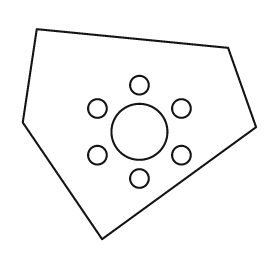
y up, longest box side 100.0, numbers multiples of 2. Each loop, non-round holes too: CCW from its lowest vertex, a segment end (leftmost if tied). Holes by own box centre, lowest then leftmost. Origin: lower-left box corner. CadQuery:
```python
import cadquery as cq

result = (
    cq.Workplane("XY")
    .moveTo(34.0, 0.0)
    .lineTo(100.0, 48.0)
    .lineTo(88.0, 82.0)
    .lineTo(6.0, 90.0)
    .lineTo(0.0, 50.0)
    .close()
    .moveTo(50.0, 26.0)
    .circle(4.0)
    .moveTo(32.0, 36.0)
    .circle(4.0)
    .moveTo(68.0, 36.0)
    .circle(4.0)
    .moveTo(50.0, 46.0)
    .circle(12.0)
    .moveTo(32.0, 56.0)
    .circle(4.0)
    .moveTo(68.0, 56.0)
    .circle(4.0)
    .moveTo(50.0, 66.0)
    .circle(4.0)
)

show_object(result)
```